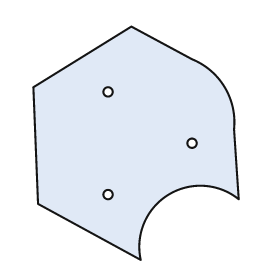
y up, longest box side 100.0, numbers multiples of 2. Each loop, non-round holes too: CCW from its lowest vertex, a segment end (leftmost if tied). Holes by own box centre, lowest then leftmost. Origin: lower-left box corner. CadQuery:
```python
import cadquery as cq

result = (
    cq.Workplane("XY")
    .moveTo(46.0, 0.0)
    .threePointArc((58.0, 28.0), (88.0, 26.0))
    .lineTo(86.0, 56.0)
    .threePointArc((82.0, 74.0), (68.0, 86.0))
    .lineTo(42.0, 100.0)
    .lineTo(0.0, 74.0)
    .lineTo(2.0, 24.0)
    .close()
    .moveTo(32.0, 28.0)
    .circle(2.0)
    .moveTo(68.0, 50.0)
    .circle(2.0)
    .moveTo(32.0, 72.0)
    .circle(2.0)
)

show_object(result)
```